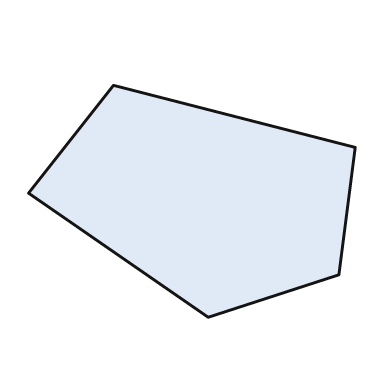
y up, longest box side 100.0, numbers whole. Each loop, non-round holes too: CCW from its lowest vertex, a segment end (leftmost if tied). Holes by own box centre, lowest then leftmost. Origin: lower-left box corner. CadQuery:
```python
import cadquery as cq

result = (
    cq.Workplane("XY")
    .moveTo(55.0, 0.0)
    .lineTo(95.0, 13.0)
    .lineTo(100.0, 52.0)
    .lineTo(26.0, 71.0)
    .lineTo(0.0, 38.0)
    .close()
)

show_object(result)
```